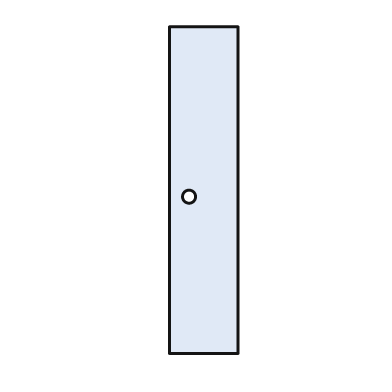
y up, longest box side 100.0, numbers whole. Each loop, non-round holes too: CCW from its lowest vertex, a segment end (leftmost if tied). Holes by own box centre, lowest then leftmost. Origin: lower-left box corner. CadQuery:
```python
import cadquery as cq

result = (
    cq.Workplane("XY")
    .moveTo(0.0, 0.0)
    .lineTo(21.0, 0.0)
    .lineTo(21.0, 100.0)
    .lineTo(0.0, 100.0)
    .close()
    .moveTo(6.0, 48.0)
    .circle(2.0)
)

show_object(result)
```